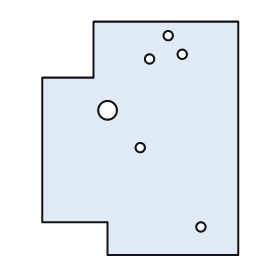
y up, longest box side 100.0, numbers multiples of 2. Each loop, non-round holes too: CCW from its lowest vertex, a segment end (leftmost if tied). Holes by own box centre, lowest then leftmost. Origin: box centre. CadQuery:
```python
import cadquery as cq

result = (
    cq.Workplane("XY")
    .moveTo(-14.0, -50.0)
    .lineTo(42.0, -50.0)
    .lineTo(42.0, 50.0)
    .lineTo(-20.0, 50.0)
    .lineTo(-20.0, 26.0)
    .lineTo(-42.0, 26.0)
    .lineTo(-42.0, -36.0)
    .lineTo(-14.0, -36.0)
    .close()
    .moveTo(26.0, -38.0)
    .circle(2.0)
    .moveTo(0.0, -4.0)
    .circle(2.0)
    .moveTo(-14.0, 12.0)
    .circle(4.0)
    .moveTo(4.0, 34.0)
    .circle(2.0)
    .moveTo(18.0, 36.0)
    .circle(2.0)
    .moveTo(12.0, 44.0)
    .circle(2.0)
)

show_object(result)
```